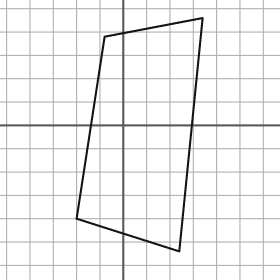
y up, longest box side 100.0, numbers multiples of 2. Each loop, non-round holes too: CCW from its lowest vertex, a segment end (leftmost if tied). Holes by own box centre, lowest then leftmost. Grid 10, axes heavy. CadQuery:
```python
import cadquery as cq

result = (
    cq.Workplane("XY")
    .moveTo(24.0, -54.0)
    .lineTo(34.0, 46.0)
    .lineTo(-8.0, 38.0)
    .lineTo(-20.0, -40.0)
    .close()
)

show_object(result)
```